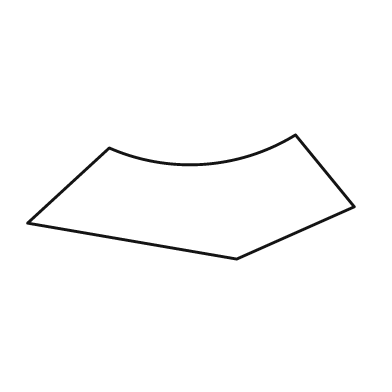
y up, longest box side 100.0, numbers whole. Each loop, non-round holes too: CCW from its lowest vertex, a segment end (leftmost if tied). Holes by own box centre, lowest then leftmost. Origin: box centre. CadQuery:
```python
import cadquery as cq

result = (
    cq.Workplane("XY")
    .moveTo(14.0, -19.0)
    .lineTo(50.0, -3.0)
    .lineTo(32.0, 19.0)
    .threePointArc((4.0, 10.0), (-25.0, 15.0))
    .lineTo(-50.0, -8.0)
    .close()
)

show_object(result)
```